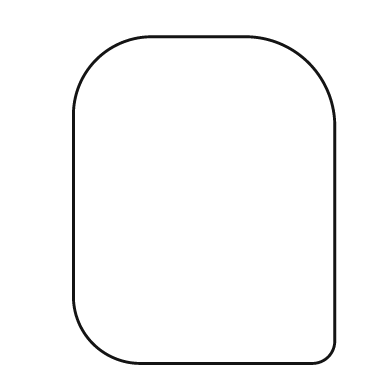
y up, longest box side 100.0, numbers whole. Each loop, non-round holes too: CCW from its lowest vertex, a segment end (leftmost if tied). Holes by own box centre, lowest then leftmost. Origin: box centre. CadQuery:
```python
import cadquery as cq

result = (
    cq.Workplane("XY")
    .moveTo(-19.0, -50.0)
    .lineTo(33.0, -50.0)
    .threePointArc((38.0, -48.0), (40.0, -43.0))
    .lineTo(40.0, 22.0)
    .threePointArc((32.0, 42.0), (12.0, 50.0))
    .lineTo(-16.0, 50.0)
    .threePointArc((-33.0, 43.0), (-40.0, 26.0))
    .lineTo(-40.0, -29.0)
    .threePointArc((-34.0, -44.0), (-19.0, -50.0))
    .close()
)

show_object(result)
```